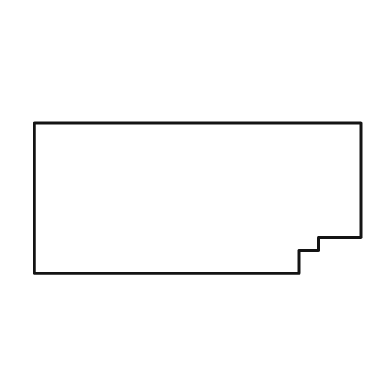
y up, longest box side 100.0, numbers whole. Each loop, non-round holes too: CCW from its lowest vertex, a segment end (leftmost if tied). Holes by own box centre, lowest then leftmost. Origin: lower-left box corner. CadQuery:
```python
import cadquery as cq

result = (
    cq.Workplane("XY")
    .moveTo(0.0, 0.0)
    .lineTo(81.0, 0.0)
    .lineTo(81.0, 7.0)
    .lineTo(87.0, 7.0)
    .lineTo(87.0, 11.0)
    .lineTo(100.0, 11.0)
    .lineTo(100.0, 46.0)
    .lineTo(0.0, 46.0)
    .close()
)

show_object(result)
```